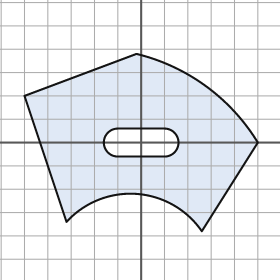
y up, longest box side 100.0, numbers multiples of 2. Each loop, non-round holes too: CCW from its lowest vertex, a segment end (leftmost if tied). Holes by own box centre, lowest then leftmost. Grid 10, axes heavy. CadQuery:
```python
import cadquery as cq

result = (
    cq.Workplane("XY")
    .moveTo(26.0, -38.0)
    .lineTo(50.0, 0.0)
    .threePointArc((28.0, 24.0), (-2.0, 38.0))
    .lineTo(-50.0, 20.0)
    .lineTo(-32.0, -34.0)
    .threePointArc((-2.0, -22.0), (26.0, -38.0))
    .close()
    .moveTo(-10.0, -6.0)
    .lineTo(10.0, -6.0)
    .threePointArc((16.0, 0.0), (10.0, 6.0))
    .lineTo(-10.0, 6.0)
    .threePointArc((-16.0, 0.0), (-10.0, -6.0))
    .close()
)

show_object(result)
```